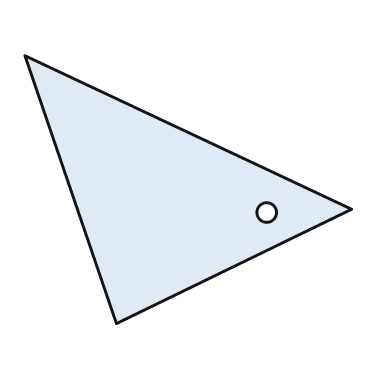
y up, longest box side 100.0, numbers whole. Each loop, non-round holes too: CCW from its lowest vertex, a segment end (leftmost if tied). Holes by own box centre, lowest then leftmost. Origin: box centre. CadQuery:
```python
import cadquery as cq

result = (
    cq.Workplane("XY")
    .moveTo(-22.0, -41.0)
    .lineTo(50.0, -6.0)
    .lineTo(-50.0, 41.0)
    .close()
    .moveTo(24.0, -7.0)
    .circle(3.0)
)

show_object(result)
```